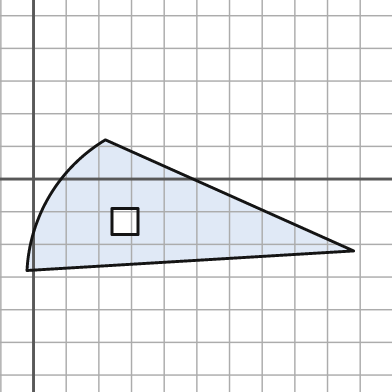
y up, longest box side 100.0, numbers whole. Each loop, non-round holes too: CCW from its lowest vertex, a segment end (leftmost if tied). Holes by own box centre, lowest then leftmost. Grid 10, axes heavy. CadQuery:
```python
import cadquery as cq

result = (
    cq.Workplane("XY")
    .moveTo(-2.0, -28.0)
    .lineTo(98.0, -22.0)
    .lineTo(22.0, 12.0)
    .threePointArc((5.0, -5.0), (-2.0, -28.0))
    .close()
    .moveTo(24.0, -17.0)
    .lineTo(32.0, -17.0)
    .lineTo(32.0, -9.0)
    .lineTo(24.0, -9.0)
    .close()
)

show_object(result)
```